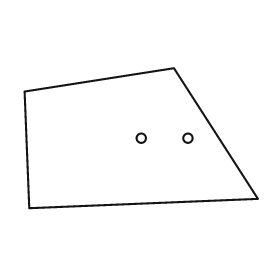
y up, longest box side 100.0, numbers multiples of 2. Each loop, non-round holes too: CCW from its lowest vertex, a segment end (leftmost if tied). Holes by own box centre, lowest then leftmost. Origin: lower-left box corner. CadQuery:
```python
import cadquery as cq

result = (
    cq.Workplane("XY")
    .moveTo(2.0, 0.0)
    .lineTo(100.0, 4.0)
    .lineTo(64.0, 60.0)
    .lineTo(0.0, 50.0)
    .close()
    .moveTo(50.0, 30.0)
    .circle(2.0)
    .moveTo(70.0, 30.0)
    .circle(2.0)
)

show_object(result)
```